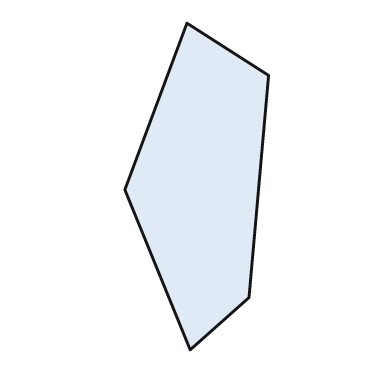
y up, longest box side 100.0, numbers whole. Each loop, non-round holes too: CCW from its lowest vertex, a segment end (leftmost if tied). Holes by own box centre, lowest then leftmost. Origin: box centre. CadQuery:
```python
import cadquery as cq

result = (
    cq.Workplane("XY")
    .moveTo(-2.0, -50.0)
    .lineTo(16.0, -34.0)
    .lineTo(22.0, 34.0)
    .lineTo(-3.0, 50.0)
    .lineTo(-22.0, -1.0)
    .close()
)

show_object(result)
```